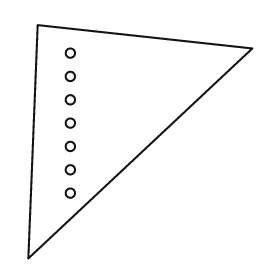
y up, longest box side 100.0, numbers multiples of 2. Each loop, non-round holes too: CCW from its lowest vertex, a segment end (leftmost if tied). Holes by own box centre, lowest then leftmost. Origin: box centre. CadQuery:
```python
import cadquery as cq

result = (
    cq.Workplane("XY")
    .moveTo(-48.0, -50.0)
    .lineTo(48.0, 40.0)
    .lineTo(-44.0, 50.0)
    .close()
    .moveTo(-30.0, -22.0)
    .circle(2.0)
    .moveTo(-30.0, -12.0)
    .circle(2.0)
    .moveTo(-30.0, -2.0)
    .circle(2.0)
    .moveTo(-30.0, 8.0)
    .circle(2.0)
    .moveTo(-30.0, 18.0)
    .circle(2.0)
    .moveTo(-30.0, 28.0)
    .circle(2.0)
    .moveTo(-30.0, 38.0)
    .circle(2.0)
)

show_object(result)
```